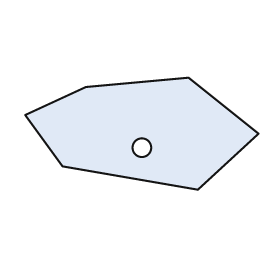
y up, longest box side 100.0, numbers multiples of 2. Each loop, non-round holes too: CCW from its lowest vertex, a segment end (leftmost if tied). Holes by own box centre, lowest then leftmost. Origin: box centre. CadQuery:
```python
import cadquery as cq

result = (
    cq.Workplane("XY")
    .moveTo(24.0, -24.0)
    .lineTo(50.0, 0.0)
    .lineTo(20.0, 24.0)
    .lineTo(-24.0, 20.0)
    .lineTo(-50.0, 8.0)
    .lineTo(-34.0, -14.0)
    .close()
    .moveTo(0.0, -6.0)
    .circle(4.0)
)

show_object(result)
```